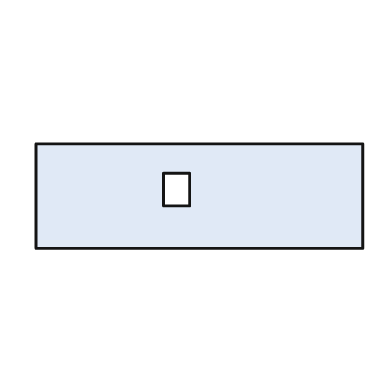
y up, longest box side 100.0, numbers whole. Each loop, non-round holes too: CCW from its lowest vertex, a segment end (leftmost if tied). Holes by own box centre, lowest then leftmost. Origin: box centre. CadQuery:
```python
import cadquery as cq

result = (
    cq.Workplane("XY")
    .moveTo(-50.0, -16.0)
    .lineTo(50.0, -16.0)
    .lineTo(50.0, 16.0)
    .lineTo(-50.0, 16.0)
    .close()
    .moveTo(-11.0, -3.0)
    .lineTo(-3.0, -3.0)
    .lineTo(-3.0, 7.0)
    .lineTo(-11.0, 7.0)
    .close()
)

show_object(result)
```